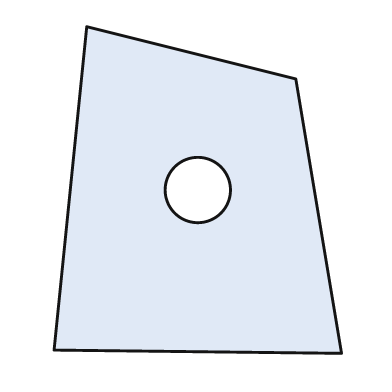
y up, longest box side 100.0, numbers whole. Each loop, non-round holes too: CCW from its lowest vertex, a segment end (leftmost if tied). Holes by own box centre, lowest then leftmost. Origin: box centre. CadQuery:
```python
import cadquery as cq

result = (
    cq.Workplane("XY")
    .moveTo(44.0, -50.0)
    .lineTo(30.0, 34.0)
    .lineTo(-34.0, 50.0)
    .lineTo(-44.0, -49.0)
    .close()
    .moveTo(0.0, 0.0)
    .circle(10.0)
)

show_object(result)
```